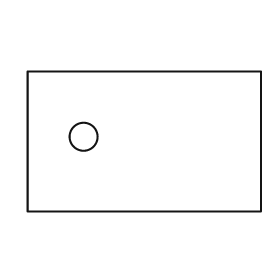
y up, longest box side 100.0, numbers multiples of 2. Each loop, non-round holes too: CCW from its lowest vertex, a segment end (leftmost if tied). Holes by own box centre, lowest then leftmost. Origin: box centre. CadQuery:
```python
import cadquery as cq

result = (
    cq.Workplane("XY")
    .moveTo(-50.0, -30.0)
    .lineTo(50.0, -30.0)
    .lineTo(50.0, 30.0)
    .lineTo(-50.0, 30.0)
    .close()
    .moveTo(-26.0, 2.0)
    .circle(6.0)
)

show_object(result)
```